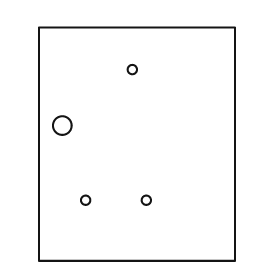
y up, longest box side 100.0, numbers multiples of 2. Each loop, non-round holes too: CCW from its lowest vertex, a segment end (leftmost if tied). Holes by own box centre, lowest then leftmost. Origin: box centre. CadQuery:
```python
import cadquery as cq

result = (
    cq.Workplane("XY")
    .moveTo(-42.0, -50.0)
    .lineTo(42.0, -50.0)
    .lineTo(42.0, 50.0)
    .lineTo(-42.0, 50.0)
    .close()
    .moveTo(-22.0, -24.0)
    .circle(2.0)
    .moveTo(4.0, -24.0)
    .circle(2.0)
    .moveTo(-32.0, 8.0)
    .circle(4.0)
    .moveTo(-2.0, 32.0)
    .circle(2.0)
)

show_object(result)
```